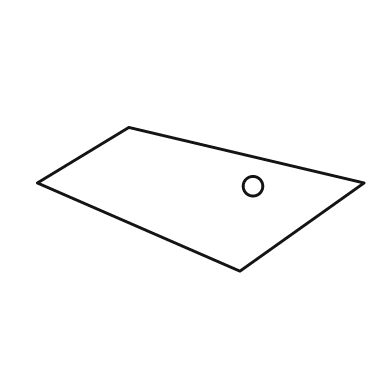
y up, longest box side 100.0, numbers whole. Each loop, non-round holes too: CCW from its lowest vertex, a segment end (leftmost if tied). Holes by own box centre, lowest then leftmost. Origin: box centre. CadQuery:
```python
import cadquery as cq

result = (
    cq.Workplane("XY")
    .moveTo(12.0, -22.0)
    .lineTo(50.0, 5.0)
    .lineTo(-22.0, 22.0)
    .lineTo(-50.0, 5.0)
    .close()
    .moveTo(16.0, 4.0)
    .circle(3.0)
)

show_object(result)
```